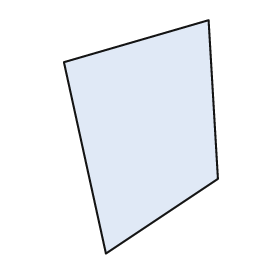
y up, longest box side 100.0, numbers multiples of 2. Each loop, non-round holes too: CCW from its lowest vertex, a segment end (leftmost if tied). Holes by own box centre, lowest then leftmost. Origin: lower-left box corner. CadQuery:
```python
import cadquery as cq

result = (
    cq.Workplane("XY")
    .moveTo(18.0, 0.0)
    .lineTo(66.0, 32.0)
    .lineTo(62.0, 100.0)
    .lineTo(0.0, 82.0)
    .close()
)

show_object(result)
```